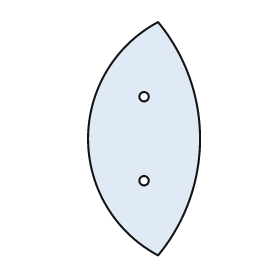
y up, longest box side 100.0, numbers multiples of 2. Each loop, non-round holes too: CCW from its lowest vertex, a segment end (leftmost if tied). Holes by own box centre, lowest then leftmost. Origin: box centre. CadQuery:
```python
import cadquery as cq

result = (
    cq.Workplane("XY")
    .moveTo(6.0, -50.0)
    .threePointArc((24.0, 0.0), (6.0, 50.0))
    .threePointArc((-24.0, 0.0), (6.0, -50.0))
    .close()
    .moveTo(0.0, -18.0)
    .circle(2.0)
    .moveTo(0.0, 18.0)
    .circle(2.0)
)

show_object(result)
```